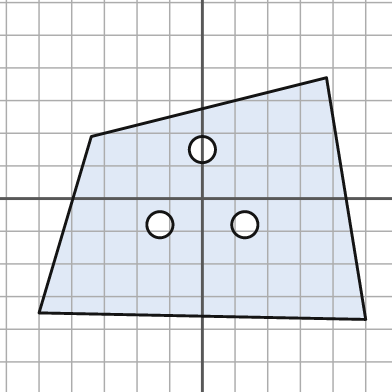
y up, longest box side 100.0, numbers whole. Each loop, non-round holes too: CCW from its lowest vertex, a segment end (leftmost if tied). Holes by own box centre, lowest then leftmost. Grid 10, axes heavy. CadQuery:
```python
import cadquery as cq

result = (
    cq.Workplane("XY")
    .moveTo(50.0, -37.0)
    .lineTo(38.0, 37.0)
    .lineTo(-34.0, 19.0)
    .lineTo(-50.0, -35.0)
    .close()
    .moveTo(-13.0, -8.0)
    .circle(4.0)
    .moveTo(13.0, -8.0)
    .circle(4.0)
    .moveTo(0.0, 15.0)
    .circle(4.0)
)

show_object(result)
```